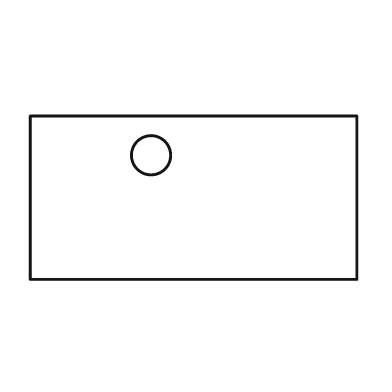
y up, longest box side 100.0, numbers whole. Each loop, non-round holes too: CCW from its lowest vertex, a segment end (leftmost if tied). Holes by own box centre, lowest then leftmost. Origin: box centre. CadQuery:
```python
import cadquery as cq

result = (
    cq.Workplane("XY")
    .moveTo(-50.0, -25.0)
    .lineTo(50.0, -25.0)
    .lineTo(50.0, 25.0)
    .lineTo(-50.0, 25.0)
    .close()
    .moveTo(-13.0, 13.0)
    .circle(6.0)
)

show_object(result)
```